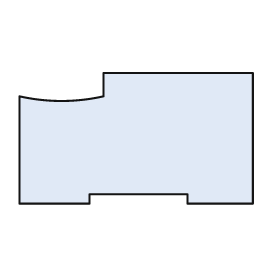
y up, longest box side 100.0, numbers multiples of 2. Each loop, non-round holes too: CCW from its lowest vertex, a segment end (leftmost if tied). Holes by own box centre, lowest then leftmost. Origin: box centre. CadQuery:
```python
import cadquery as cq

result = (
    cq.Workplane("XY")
    .moveTo(-50.0, -28.0)
    .lineTo(-20.0, -28.0)
    .lineTo(-20.0, -24.0)
    .lineTo(22.0, -24.0)
    .lineTo(22.0, -28.0)
    .lineTo(50.0, -28.0)
    .lineTo(50.0, 28.0)
    .lineTo(-14.0, 28.0)
    .lineTo(-14.0, 18.0)
    .threePointArc((-32.0, 16.0), (-50.0, 18.0))
    .close()
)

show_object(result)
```